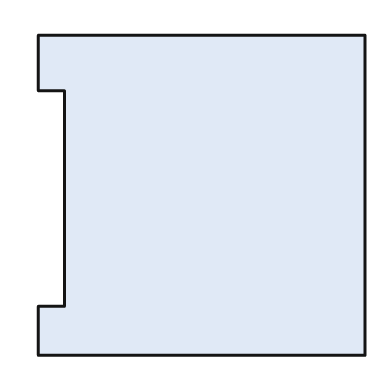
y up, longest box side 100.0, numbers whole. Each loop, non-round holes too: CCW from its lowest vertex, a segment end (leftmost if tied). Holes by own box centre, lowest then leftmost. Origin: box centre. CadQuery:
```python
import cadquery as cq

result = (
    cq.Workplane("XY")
    .moveTo(-50.0, -49.0)
    .lineTo(50.0, -49.0)
    .lineTo(50.0, 49.0)
    .lineTo(-50.0, 49.0)
    .lineTo(-50.0, 32.0)
    .lineTo(-42.0, 32.0)
    .lineTo(-42.0, -34.0)
    .lineTo(-50.0, -34.0)
    .close()
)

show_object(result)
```